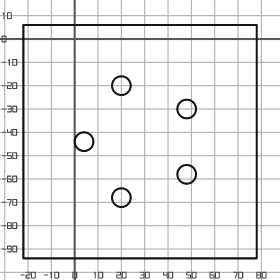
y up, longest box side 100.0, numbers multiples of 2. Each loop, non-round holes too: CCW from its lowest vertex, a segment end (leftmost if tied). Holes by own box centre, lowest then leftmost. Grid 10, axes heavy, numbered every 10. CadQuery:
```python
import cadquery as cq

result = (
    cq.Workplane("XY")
    .moveTo(-22.0, -94.0)
    .lineTo(78.0, -94.0)
    .lineTo(78.0, 6.0)
    .lineTo(-22.0, 6.0)
    .close()
    .moveTo(20.0, -68.0)
    .circle(4.0)
    .moveTo(48.0, -58.0)
    .circle(4.0)
    .moveTo(4.0, -44.0)
    .circle(4.0)
    .moveTo(48.0, -30.0)
    .circle(4.0)
    .moveTo(20.0, -20.0)
    .circle(4.0)
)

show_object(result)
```